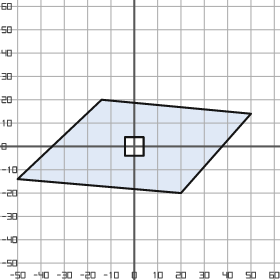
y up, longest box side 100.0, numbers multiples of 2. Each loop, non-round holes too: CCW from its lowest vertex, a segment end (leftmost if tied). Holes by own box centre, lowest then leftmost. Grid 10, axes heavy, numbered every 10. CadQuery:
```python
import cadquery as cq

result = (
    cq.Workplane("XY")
    .moveTo(20.0, -20.0)
    .lineTo(50.0, 14.0)
    .lineTo(-14.0, 20.0)
    .lineTo(-50.0, -14.0)
    .close()
    .moveTo(-4.0, -4.0)
    .lineTo(4.0, -4.0)
    .lineTo(4.0, 4.0)
    .lineTo(-4.0, 4.0)
    .close()
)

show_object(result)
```